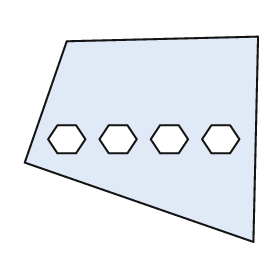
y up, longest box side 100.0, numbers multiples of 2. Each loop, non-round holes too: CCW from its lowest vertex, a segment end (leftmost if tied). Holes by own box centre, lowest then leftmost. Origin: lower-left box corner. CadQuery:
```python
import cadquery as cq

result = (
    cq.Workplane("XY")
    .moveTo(98.0, 0.0)
    .lineTo(100.0, 88.0)
    .lineTo(18.0, 86.0)
    .lineTo(0.0, 34.0)
    .close()
    .moveTo(14.0, 38.0)
    .lineTo(22.0, 38.0)
    .lineTo(26.0, 44.0)
    .lineTo(22.0, 50.0)
    .lineTo(14.0, 50.0)
    .lineTo(10.0, 44.0)
    .close()
    .moveTo(36.0, 38.0)
    .lineTo(44.0, 38.0)
    .lineTo(48.0, 44.0)
    .lineTo(44.0, 50.0)
    .lineTo(36.0, 50.0)
    .lineTo(32.0, 44.0)
    .close()
    .moveTo(58.0, 38.0)
    .lineTo(66.0, 38.0)
    .lineTo(70.0, 44.0)
    .lineTo(66.0, 50.0)
    .lineTo(58.0, 50.0)
    .lineTo(54.0, 44.0)
    .close()
    .moveTo(80.0, 38.0)
    .lineTo(88.0, 38.0)
    .lineTo(92.0, 44.0)
    .lineTo(88.0, 50.0)
    .lineTo(80.0, 50.0)
    .lineTo(76.0, 44.0)
    .close()
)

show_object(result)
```